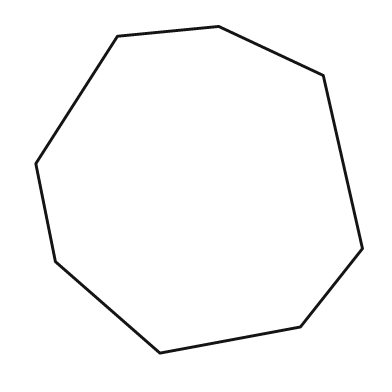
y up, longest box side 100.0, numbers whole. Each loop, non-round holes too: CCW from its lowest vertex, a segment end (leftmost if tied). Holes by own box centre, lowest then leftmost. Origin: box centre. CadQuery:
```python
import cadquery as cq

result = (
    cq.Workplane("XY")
    .moveTo(-12.0, -50.0)
    .lineTo(31.0, -42.0)
    .lineTo(50.0, -18.0)
    .lineTo(38.0, 35.0)
    .lineTo(6.0, 50.0)
    .lineTo(-25.0, 47.0)
    .lineTo(-50.0, 8.0)
    .lineTo(-44.0, -22.0)
    .close()
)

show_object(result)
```